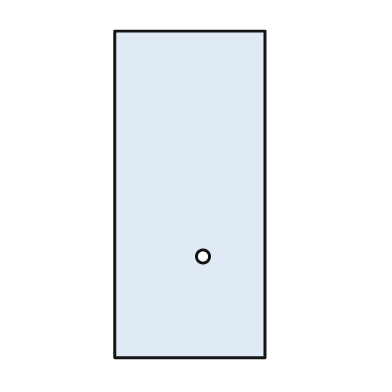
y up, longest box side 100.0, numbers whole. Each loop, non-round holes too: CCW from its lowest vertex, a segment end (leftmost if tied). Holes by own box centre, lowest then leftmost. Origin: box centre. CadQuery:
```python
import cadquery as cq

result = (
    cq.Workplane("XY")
    .moveTo(-23.0, -50.0)
    .lineTo(23.0, -50.0)
    .lineTo(23.0, 50.0)
    .lineTo(-23.0, 50.0)
    .close()
    .moveTo(4.0, -19.0)
    .circle(2.0)
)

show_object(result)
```